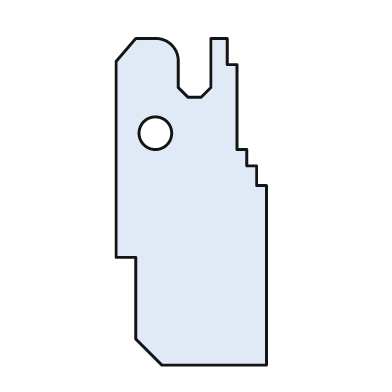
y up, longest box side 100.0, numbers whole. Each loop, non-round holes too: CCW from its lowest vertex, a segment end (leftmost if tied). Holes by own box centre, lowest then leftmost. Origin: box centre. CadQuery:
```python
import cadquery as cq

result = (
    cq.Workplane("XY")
    .moveTo(-9.0, -50.0)
    .lineTo(23.0, -50.0)
    .lineTo(23.0, 5.0)
    .lineTo(20.0, 5.0)
    .lineTo(20.0, 11.0)
    .lineTo(17.0, 11.0)
    .lineTo(17.0, 16.0)
    .lineTo(14.0, 16.0)
    .lineTo(14.0, 42.0)
    .lineTo(11.0, 42.0)
    .lineTo(11.0, 50.0)
    .lineTo(6.0, 50.0)
    .lineTo(6.0, 35.0)
    .lineTo(3.0, 32.0)
    .lineTo(-1.0, 32.0)
    .lineTo(-4.0, 35.0)
    .lineTo(-4.0, 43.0)
    .threePointArc((-6.0, 48.0), (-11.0, 50.0))
    .lineTo(-17.0, 50.0)
    .lineTo(-23.0, 43.0)
    .lineTo(-23.0, -17.0)
    .lineTo(-17.0, -17.0)
    .lineTo(-17.0, -42.0)
    .close()
    .moveTo(-11.0, 21.0)
    .circle(5.0)
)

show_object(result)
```